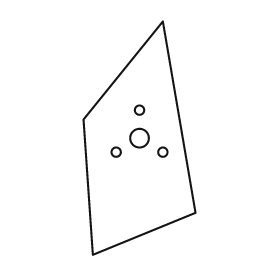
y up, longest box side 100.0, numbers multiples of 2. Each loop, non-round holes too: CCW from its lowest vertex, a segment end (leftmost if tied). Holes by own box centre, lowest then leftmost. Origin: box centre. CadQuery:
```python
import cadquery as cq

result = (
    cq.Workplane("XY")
    .moveTo(-20.0, -50.0)
    .lineTo(24.0, -32.0)
    .lineTo(10.0, 50.0)
    .lineTo(-24.0, 8.0)
    .close()
    .moveTo(-10.0, -6.0)
    .circle(2.0)
    .moveTo(10.0, -6.0)
    .circle(2.0)
    .moveTo(0.0, 0.0)
    .circle(4.0)
    .moveTo(0.0, 12.0)
    .circle(2.0)
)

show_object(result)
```